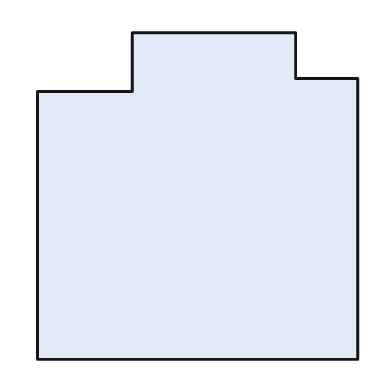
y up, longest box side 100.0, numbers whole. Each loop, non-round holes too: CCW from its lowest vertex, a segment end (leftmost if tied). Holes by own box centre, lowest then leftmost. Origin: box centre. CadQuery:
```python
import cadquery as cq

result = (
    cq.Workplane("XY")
    .moveTo(-49.0, -50.0)
    .lineTo(49.0, -50.0)
    .lineTo(49.0, 36.0)
    .lineTo(30.0, 36.0)
    .lineTo(30.0, 50.0)
    .lineTo(-20.0, 50.0)
    .lineTo(-20.0, 32.0)
    .lineTo(-49.0, 32.0)
    .close()
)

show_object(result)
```